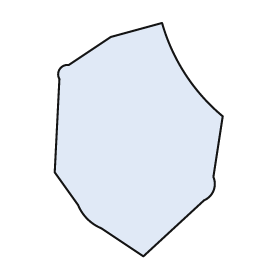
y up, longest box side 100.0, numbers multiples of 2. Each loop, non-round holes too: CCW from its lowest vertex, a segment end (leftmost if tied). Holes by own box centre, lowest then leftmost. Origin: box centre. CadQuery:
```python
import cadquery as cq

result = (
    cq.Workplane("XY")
    .moveTo(2.0, -50.0)
    .lineTo(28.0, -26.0)
    .threePointArc((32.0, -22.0), (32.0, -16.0))
    .lineTo(36.0, 10.0)
    .threePointArc((20.0, 28.0), (10.0, 50.0))
    .lineTo(-12.0, 44.0)
    .lineTo(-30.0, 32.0)
    .threePointArc((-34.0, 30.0), (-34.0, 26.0))
    .lineTo(-36.0, -14.0)
    .lineTo(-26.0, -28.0)
    .threePointArc((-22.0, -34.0), (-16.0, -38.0))
    .close()
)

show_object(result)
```